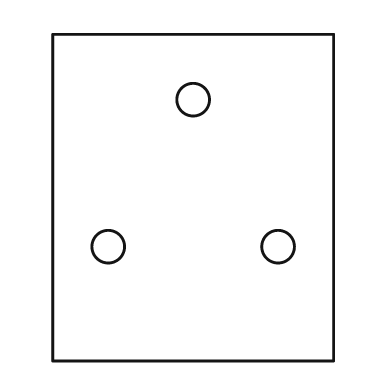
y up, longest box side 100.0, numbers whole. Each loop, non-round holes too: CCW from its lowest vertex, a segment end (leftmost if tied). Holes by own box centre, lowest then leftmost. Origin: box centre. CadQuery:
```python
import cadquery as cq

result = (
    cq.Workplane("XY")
    .moveTo(-43.0, -50.0)
    .lineTo(43.0, -50.0)
    .lineTo(43.0, 50.0)
    .lineTo(-43.0, 50.0)
    .close()
    .moveTo(-26.0, -15.0)
    .circle(5.0)
    .moveTo(26.0, -15.0)
    .circle(5.0)
    .moveTo(0.0, 30.0)
    .circle(5.0)
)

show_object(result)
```